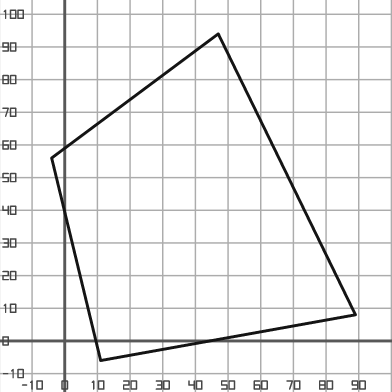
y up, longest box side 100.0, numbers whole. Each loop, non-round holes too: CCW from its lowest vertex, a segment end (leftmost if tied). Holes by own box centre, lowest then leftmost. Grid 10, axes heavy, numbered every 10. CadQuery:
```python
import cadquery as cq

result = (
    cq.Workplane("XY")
    .moveTo(11.0, -6.0)
    .lineTo(89.0, 8.0)
    .lineTo(47.0, 94.0)
    .lineTo(-4.0, 56.0)
    .close()
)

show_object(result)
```